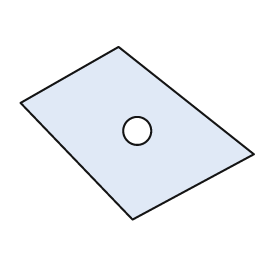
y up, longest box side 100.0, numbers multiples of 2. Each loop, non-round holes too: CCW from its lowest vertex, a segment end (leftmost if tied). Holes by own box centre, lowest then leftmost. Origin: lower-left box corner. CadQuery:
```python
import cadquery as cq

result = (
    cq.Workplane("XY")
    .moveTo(48.0, 0.0)
    .lineTo(100.0, 28.0)
    .lineTo(42.0, 74.0)
    .lineTo(0.0, 50.0)
    .close()
    .moveTo(50.0, 38.0)
    .circle(6.0)
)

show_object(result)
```